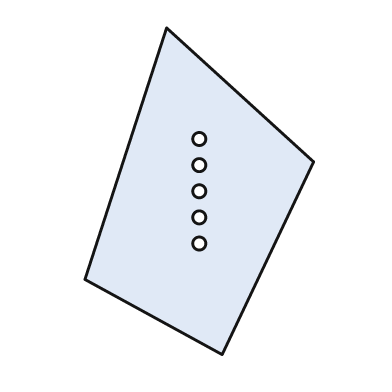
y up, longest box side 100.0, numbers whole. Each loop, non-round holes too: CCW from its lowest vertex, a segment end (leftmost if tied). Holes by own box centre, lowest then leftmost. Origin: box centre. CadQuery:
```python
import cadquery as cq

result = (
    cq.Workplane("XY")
    .moveTo(7.0, -50.0)
    .lineTo(35.0, 9.0)
    .lineTo(-10.0, 50.0)
    .lineTo(-35.0, -27.0)
    .close()
    .moveTo(0.0, -16.0)
    .circle(2.0)
    .moveTo(0.0, -8.0)
    .circle(2.0)
    .moveTo(0.0, 0.0)
    .circle(2.0)
    .moveTo(0.0, 8.0)
    .circle(2.0)
    .moveTo(0.0, 16.0)
    .circle(2.0)
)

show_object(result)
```